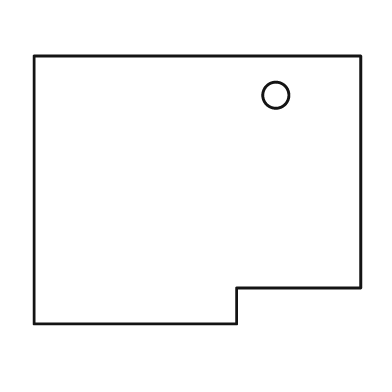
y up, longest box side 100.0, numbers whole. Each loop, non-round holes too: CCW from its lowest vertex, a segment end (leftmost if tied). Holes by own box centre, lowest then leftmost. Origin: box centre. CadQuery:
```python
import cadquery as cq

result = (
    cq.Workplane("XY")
    .moveTo(-50.0, -41.0)
    .lineTo(12.0, -41.0)
    .lineTo(12.0, -30.0)
    .lineTo(50.0, -30.0)
    .lineTo(50.0, 41.0)
    .lineTo(-50.0, 41.0)
    .close()
    .moveTo(24.0, 29.0)
    .circle(4.0)
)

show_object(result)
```